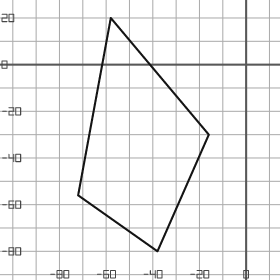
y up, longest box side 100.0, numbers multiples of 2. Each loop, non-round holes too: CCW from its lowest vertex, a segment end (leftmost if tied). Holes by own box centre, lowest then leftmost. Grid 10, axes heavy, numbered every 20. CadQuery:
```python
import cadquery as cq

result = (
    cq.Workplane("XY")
    .moveTo(-38.0, -80.0)
    .lineTo(-16.0, -30.0)
    .lineTo(-58.0, 20.0)
    .lineTo(-72.0, -56.0)
    .close()
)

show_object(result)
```